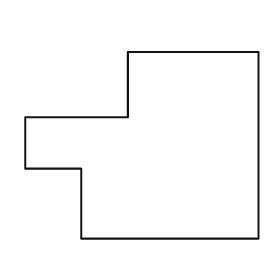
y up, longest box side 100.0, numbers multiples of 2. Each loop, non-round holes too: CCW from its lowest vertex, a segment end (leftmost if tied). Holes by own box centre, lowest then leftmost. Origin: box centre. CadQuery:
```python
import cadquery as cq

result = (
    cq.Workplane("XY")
    .moveTo(-26.0, -40.0)
    .lineTo(50.0, -40.0)
    .lineTo(50.0, 40.0)
    .lineTo(-6.0, 40.0)
    .lineTo(-6.0, 12.0)
    .lineTo(-50.0, 12.0)
    .lineTo(-50.0, -10.0)
    .lineTo(-26.0, -10.0)
    .close()
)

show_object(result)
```